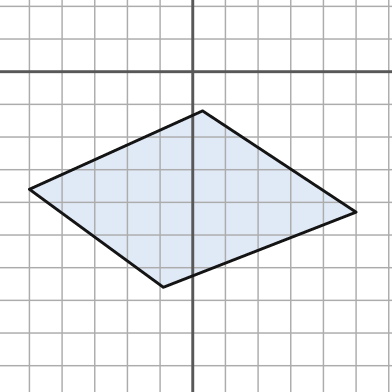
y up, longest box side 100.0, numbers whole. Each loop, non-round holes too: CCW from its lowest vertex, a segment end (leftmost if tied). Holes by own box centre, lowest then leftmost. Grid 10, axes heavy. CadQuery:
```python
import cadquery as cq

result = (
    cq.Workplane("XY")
    .moveTo(-9.0, -66.0)
    .lineTo(50.0, -43.0)
    .lineTo(3.0, -12.0)
    .lineTo(-50.0, -36.0)
    .close()
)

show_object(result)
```